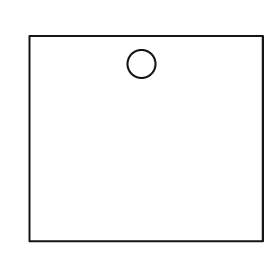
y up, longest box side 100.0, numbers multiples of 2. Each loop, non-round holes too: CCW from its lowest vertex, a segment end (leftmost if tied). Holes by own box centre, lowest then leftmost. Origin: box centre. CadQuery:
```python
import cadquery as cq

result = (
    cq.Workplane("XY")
    .moveTo(-50.0, -44.0)
    .lineTo(50.0, -44.0)
    .lineTo(50.0, 44.0)
    .lineTo(-50.0, 44.0)
    .close()
    .moveTo(-2.0, 32.0)
    .circle(6.0)
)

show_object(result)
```